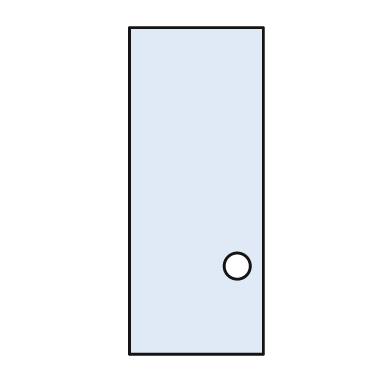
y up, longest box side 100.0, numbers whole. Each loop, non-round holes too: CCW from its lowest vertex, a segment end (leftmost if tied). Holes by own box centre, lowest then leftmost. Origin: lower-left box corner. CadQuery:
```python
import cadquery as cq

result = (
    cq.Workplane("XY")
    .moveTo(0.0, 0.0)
    .lineTo(41.0, 0.0)
    .lineTo(41.0, 100.0)
    .lineTo(0.0, 100.0)
    .close()
    .moveTo(33.0, 27.0)
    .circle(4.0)
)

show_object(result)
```